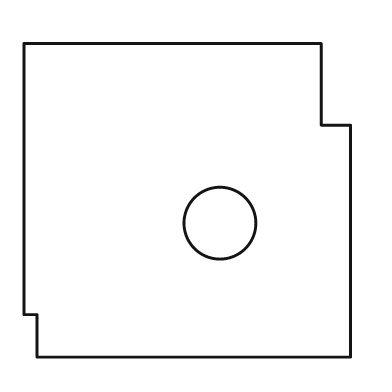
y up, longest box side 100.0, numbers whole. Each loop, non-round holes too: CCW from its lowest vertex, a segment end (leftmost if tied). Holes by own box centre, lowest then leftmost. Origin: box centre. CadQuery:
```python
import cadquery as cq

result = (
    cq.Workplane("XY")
    .moveTo(-46.0, -48.0)
    .lineTo(50.0, -48.0)
    .lineTo(50.0, 23.0)
    .lineTo(41.0, 23.0)
    .lineTo(41.0, 48.0)
    .lineTo(-50.0, 48.0)
    .lineTo(-50.0, -35.0)
    .lineTo(-46.0, -35.0)
    .close()
    .moveTo(10.0, -7.0)
    .circle(11.0)
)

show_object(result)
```